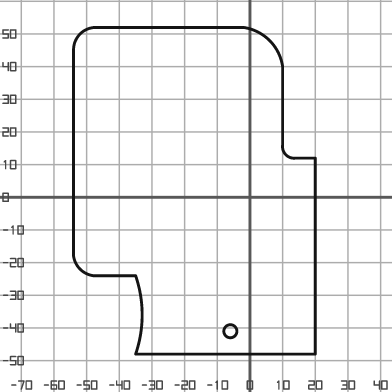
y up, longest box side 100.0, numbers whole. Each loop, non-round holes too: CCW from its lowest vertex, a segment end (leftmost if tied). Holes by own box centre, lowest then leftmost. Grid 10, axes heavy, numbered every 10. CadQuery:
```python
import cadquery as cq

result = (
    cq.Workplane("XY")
    .moveTo(-35.0, -48.0)
    .lineTo(20.0, -48.0)
    .lineTo(20.0, 12.0)
    .lineTo(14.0, 12.0)
    .threePointArc((11.0, 13.0), (10.0, 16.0))
    .lineTo(10.0, 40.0)
    .threePointArc((6.0, 48.0), (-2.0, 52.0))
    .lineTo(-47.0, 52.0)
    .threePointArc((-52.0, 50.0), (-54.0, 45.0))
    .lineTo(-54.0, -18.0)
    .threePointArc((-52.0, -22.0), (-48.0, -24.0))
    .lineTo(-35.0, -24.0)
    .threePointArc((-33.0, -36.0), (-35.0, -48.0))
    .close()
    .moveTo(-6.0, -41.0)
    .circle(2.0)
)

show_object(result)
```